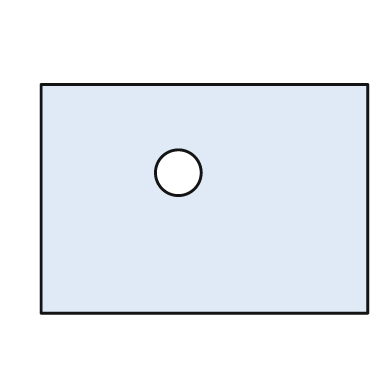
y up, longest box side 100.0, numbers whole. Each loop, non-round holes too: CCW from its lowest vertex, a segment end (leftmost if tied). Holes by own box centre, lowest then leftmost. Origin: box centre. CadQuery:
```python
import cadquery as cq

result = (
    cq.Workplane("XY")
    .moveTo(-50.0, -35.0)
    .lineTo(50.0, -35.0)
    .lineTo(50.0, 35.0)
    .lineTo(-50.0, 35.0)
    .close()
    .moveTo(-8.0, 8.0)
    .circle(7.0)
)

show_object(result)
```